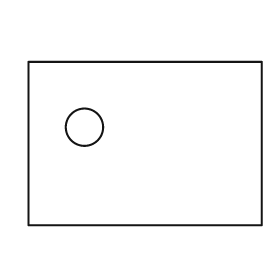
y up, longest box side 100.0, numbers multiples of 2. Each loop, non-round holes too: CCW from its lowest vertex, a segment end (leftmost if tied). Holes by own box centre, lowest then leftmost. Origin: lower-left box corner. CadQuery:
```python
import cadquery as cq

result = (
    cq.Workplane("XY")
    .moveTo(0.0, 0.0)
    .lineTo(100.0, 0.0)
    .lineTo(100.0, 70.0)
    .lineTo(0.0, 70.0)
    .close()
    .moveTo(24.0, 42.0)
    .circle(8.0)
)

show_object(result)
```